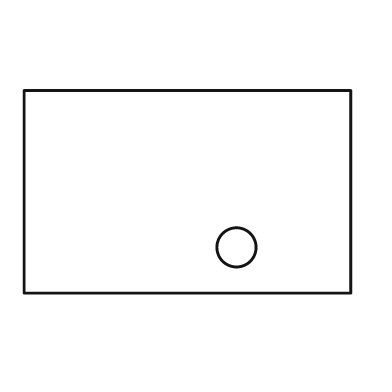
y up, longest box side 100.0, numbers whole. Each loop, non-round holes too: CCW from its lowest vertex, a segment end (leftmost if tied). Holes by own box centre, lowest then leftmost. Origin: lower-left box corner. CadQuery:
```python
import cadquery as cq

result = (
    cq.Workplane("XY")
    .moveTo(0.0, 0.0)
    .lineTo(100.0, 0.0)
    .lineTo(100.0, 62.0)
    .lineTo(0.0, 62.0)
    .close()
    .moveTo(65.0, 14.0)
    .circle(6.0)
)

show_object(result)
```